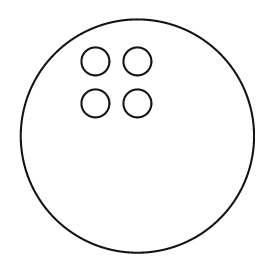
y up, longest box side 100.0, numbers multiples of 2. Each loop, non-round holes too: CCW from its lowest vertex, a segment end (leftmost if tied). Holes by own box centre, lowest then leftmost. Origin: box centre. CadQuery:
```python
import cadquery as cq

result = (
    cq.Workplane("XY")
    .moveTo(0.0, 0.0)
    .circle(50.0)
    .moveTo(-18.0, 14.0)
    .circle(6.0)
    .moveTo(0.0, 14.0)
    .circle(6.0)
    .moveTo(-18.0, 32.0)
    .circle(6.0)
    .moveTo(0.0, 32.0)
    .circle(6.0)
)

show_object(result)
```